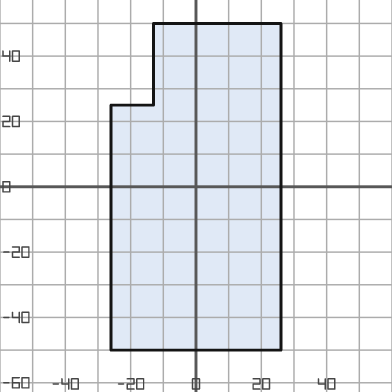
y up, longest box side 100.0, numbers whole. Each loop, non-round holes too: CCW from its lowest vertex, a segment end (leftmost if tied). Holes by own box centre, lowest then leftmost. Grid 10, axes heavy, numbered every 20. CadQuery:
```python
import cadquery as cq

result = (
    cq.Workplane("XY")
    .moveTo(-26.0, -50.0)
    .lineTo(26.0, -50.0)
    .lineTo(26.0, 50.0)
    .lineTo(-13.0, 50.0)
    .lineTo(-13.0, 25.0)
    .lineTo(-26.0, 25.0)
    .close()
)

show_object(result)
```